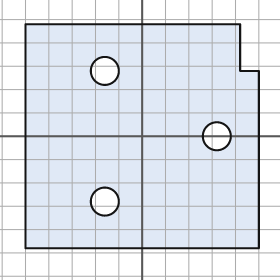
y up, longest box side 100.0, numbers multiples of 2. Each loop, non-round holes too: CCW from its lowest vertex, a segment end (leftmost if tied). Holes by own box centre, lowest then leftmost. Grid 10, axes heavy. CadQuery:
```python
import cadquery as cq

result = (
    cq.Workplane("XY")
    .moveTo(-50.0, -48.0)
    .lineTo(50.0, -48.0)
    .lineTo(50.0, 28.0)
    .lineTo(42.0, 28.0)
    .lineTo(42.0, 48.0)
    .lineTo(-50.0, 48.0)
    .close()
    .moveTo(-16.0, -28.0)
    .circle(6.0)
    .moveTo(32.0, 0.0)
    .circle(6.0)
    .moveTo(-16.0, 28.0)
    .circle(6.0)
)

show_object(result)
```